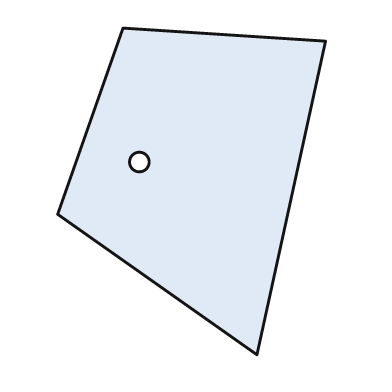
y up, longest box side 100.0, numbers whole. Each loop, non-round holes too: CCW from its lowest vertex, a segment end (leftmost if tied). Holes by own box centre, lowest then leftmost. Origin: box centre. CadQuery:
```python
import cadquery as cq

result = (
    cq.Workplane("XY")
    .moveTo(20.0, -50.0)
    .lineTo(41.0, 46.0)
    .lineTo(-21.0, 50.0)
    .lineTo(-41.0, -7.0)
    .close()
    .moveTo(-16.0, 9.0)
    .circle(3.0)
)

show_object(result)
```